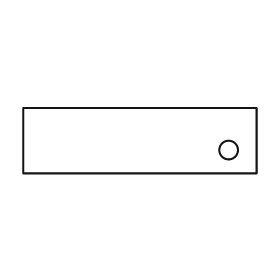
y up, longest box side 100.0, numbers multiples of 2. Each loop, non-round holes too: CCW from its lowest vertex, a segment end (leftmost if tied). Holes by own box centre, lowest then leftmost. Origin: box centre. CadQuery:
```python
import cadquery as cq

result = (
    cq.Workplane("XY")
    .moveTo(-50.0, -14.0)
    .lineTo(50.0, -14.0)
    .lineTo(50.0, 14.0)
    .lineTo(-50.0, 14.0)
    .close()
    .moveTo(38.0, -4.0)
    .circle(4.0)
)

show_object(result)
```